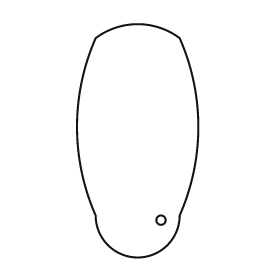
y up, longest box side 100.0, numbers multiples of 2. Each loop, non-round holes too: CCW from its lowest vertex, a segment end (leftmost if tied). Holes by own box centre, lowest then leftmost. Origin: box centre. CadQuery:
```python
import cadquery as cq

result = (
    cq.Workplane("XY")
    .moveTo(-18.0, -32.0)
    .threePointArc((0.0, -50.0), (18.0, -32.0))
    .threePointArc((26.0, 6.0), (18.0, 44.0))
    .threePointArc((0.0, 50.0), (-18.0, 44.0))
    .threePointArc((-26.0, 6.0), (-18.0, -32.0))
    .close()
    .moveTo(10.0, -34.0)
    .circle(2.0)
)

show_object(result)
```